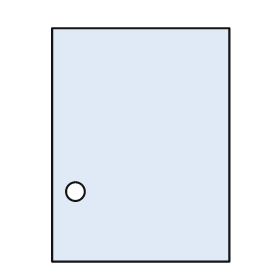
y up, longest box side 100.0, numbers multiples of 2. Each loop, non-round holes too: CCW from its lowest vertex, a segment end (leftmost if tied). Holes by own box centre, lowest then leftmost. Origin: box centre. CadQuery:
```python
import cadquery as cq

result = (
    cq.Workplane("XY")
    .moveTo(-38.0, -50.0)
    .lineTo(38.0, -50.0)
    .lineTo(38.0, 50.0)
    .lineTo(-38.0, 50.0)
    .close()
    .moveTo(-28.0, -20.0)
    .circle(4.0)
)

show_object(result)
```